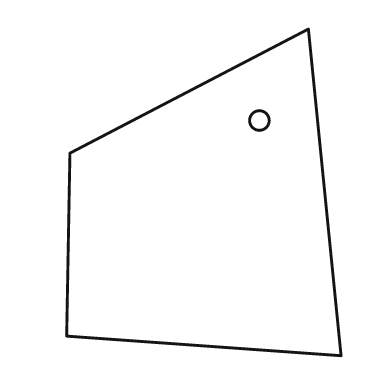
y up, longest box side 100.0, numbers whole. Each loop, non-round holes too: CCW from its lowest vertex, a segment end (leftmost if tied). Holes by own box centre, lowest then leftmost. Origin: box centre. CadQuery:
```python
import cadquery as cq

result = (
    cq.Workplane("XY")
    .moveTo(42.0, -50.0)
    .lineTo(32.0, 50.0)
    .lineTo(-41.0, 12.0)
    .lineTo(-42.0, -44.0)
    .close()
    .moveTo(17.0, 22.0)
    .circle(3.0)
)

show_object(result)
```